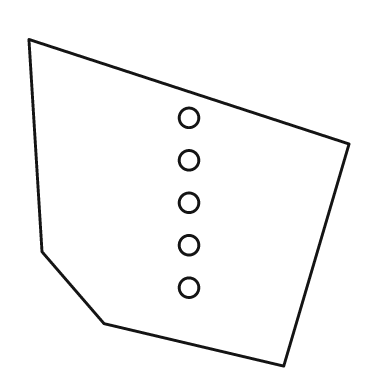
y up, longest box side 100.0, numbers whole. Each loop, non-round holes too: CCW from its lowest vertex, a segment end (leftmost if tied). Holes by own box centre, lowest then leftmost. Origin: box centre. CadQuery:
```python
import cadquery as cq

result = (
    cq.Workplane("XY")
    .moveTo(29.0, -50.0)
    .lineTo(49.0, 18.0)
    .lineTo(-49.0, 50.0)
    .lineTo(-45.0, -15.0)
    .lineTo(-26.0, -37.0)
    .close()
    .moveTo(0.0, -26.0)
    .circle(3.0)
    .moveTo(0.0, -13.0)
    .circle(3.0)
    .moveTo(0.0, 0.0)
    .circle(3.0)
    .moveTo(0.0, 13.0)
    .circle(3.0)
    .moveTo(0.0, 26.0)
    .circle(3.0)
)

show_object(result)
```